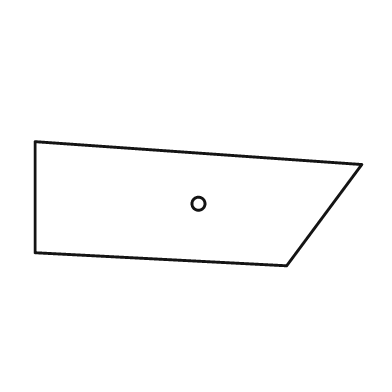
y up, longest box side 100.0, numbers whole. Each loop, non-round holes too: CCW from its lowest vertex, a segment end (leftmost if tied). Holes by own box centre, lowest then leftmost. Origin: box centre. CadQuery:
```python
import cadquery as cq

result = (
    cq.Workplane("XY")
    .moveTo(27.0, -19.0)
    .lineTo(50.0, 12.0)
    .lineTo(-50.0, 19.0)
    .lineTo(-50.0, -15.0)
    .close()
    .moveTo(0.0, 0.0)
    .circle(2.0)
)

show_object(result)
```